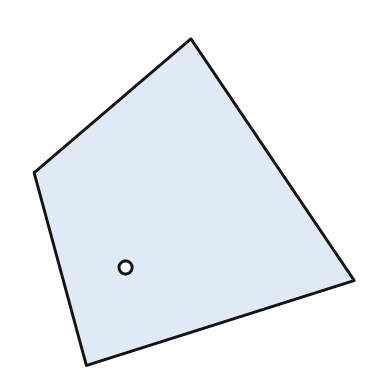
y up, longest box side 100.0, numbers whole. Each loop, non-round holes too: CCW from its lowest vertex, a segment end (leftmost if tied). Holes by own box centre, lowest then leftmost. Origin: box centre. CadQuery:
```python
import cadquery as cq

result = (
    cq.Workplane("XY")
    .moveTo(-33.0, -50.0)
    .lineTo(49.0, -24.0)
    .lineTo(-1.0, 50.0)
    .lineTo(-49.0, 9.0)
    .close()
    .moveTo(-21.0, -20.0)
    .circle(2.0)
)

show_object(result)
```